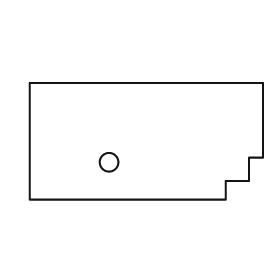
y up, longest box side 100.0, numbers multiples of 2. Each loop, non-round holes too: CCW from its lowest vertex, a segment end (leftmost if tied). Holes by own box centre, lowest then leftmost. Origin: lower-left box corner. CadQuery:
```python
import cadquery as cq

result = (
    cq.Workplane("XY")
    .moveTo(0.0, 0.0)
    .lineTo(84.0, 0.0)
    .lineTo(84.0, 8.0)
    .lineTo(94.0, 8.0)
    .lineTo(94.0, 18.0)
    .lineTo(100.0, 18.0)
    .lineTo(100.0, 50.0)
    .lineTo(0.0, 50.0)
    .close()
    .moveTo(34.0, 16.0)
    .circle(4.0)
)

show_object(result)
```